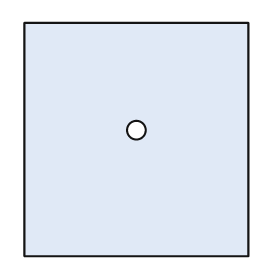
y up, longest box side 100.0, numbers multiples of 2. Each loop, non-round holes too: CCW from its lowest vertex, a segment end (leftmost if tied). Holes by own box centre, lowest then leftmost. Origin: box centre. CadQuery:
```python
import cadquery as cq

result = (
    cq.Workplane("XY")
    .moveTo(-48.0, -50.0)
    .lineTo(48.0, -50.0)
    .lineTo(48.0, 50.0)
    .lineTo(-48.0, 50.0)
    .close()
    .moveTo(0.0, 4.0)
    .circle(4.0)
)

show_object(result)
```